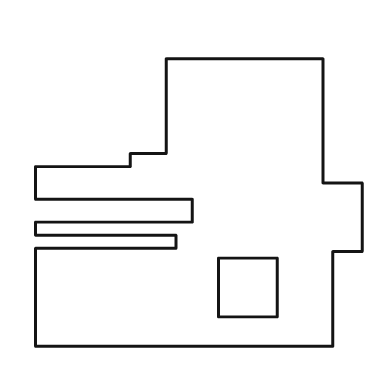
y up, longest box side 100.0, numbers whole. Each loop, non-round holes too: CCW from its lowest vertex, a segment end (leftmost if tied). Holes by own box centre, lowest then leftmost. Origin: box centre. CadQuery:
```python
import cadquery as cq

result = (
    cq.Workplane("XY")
    .moveTo(-50.0, -44.0)
    .lineTo(41.0, -44.0)
    .lineTo(41.0, -15.0)
    .lineTo(50.0, -15.0)
    .lineTo(50.0, 6.0)
    .lineTo(38.0, 6.0)
    .lineTo(38.0, 44.0)
    .lineTo(-10.0, 44.0)
    .lineTo(-10.0, 15.0)
    .lineTo(-21.0, 15.0)
    .lineTo(-21.0, 11.0)
    .lineTo(-50.0, 11.0)
    .lineTo(-50.0, 1.0)
    .lineTo(-2.0, 1.0)
    .lineTo(-2.0, -6.0)
    .lineTo(-50.0, -6.0)
    .lineTo(-50.0, -10.0)
    .lineTo(-7.0, -10.0)
    .lineTo(-7.0, -14.0)
    .lineTo(-50.0, -14.0)
    .close()
    .moveTo(6.0, -35.0)
    .lineTo(24.0, -35.0)
    .lineTo(24.0, -17.0)
    .lineTo(6.0, -17.0)
    .close()
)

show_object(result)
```